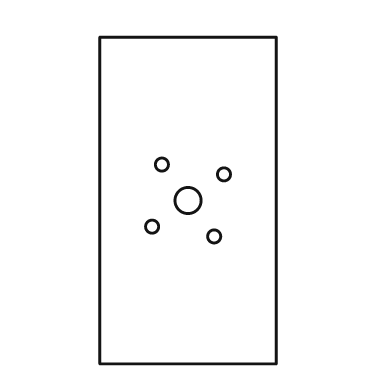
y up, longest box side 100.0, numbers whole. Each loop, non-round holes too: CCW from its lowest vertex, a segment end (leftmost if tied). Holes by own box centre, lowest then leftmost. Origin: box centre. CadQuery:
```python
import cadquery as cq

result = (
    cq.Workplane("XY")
    .moveTo(-27.0, -50.0)
    .lineTo(27.0, -50.0)
    .lineTo(27.0, 50.0)
    .lineTo(-27.0, 50.0)
    .close()
    .moveTo(8.0, -11.0)
    .circle(2.0)
    .moveTo(-11.0, -8.0)
    .circle(2.0)
    .moveTo(0.0, 0.0)
    .circle(4.0)
    .moveTo(11.0, 8.0)
    .circle(2.0)
    .moveTo(-8.0, 11.0)
    .circle(2.0)
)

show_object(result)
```